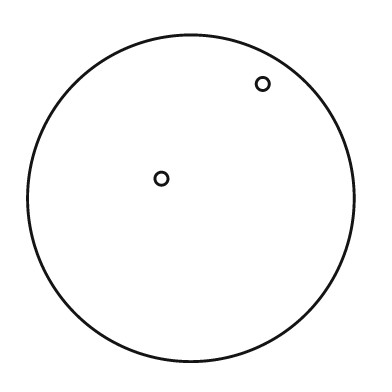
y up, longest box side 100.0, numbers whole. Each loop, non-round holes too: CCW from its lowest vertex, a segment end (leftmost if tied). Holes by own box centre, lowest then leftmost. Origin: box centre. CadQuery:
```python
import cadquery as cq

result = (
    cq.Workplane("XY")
    .moveTo(0.0, 0.0)
    .circle(50.0)
    .moveTo(-9.0, 6.0)
    .circle(2.0)
    .moveTo(22.0, 35.0)
    .circle(2.0)
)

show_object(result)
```